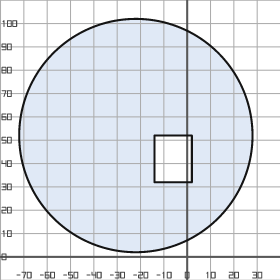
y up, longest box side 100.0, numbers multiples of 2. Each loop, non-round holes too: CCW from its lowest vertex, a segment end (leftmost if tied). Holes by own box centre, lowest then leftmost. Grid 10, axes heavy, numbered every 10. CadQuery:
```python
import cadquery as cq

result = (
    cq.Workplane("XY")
    .moveTo(-22.0, 52.0)
    .circle(50.0)
    .moveTo(-14.0, 32.0)
    .lineTo(2.0, 32.0)
    .lineTo(2.0, 52.0)
    .lineTo(-14.0, 52.0)
    .close()
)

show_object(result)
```